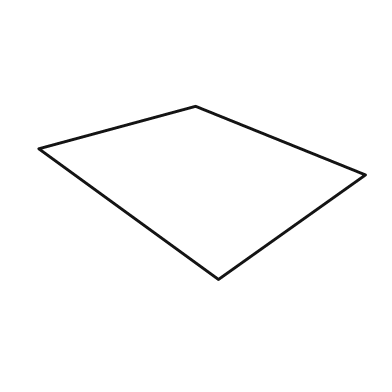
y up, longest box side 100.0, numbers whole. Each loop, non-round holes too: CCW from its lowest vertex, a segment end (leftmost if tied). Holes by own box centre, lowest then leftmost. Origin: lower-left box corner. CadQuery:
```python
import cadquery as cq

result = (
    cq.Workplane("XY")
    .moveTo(55.0, 0.0)
    .lineTo(100.0, 32.0)
    .lineTo(48.0, 53.0)
    .lineTo(0.0, 40.0)
    .close()
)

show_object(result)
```